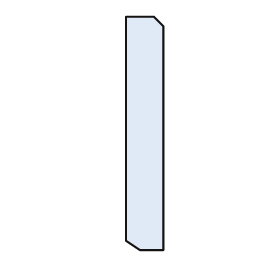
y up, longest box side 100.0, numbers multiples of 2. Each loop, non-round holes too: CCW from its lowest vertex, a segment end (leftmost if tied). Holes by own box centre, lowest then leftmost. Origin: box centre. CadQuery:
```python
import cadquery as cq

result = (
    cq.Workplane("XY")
    .moveTo(-2.0, -50.0)
    .lineTo(8.0, -50.0)
    .lineTo(8.0, 46.0)
    .lineTo(4.0, 50.0)
    .lineTo(-8.0, 50.0)
    .lineTo(-8.0, -46.0)
    .close()
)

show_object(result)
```